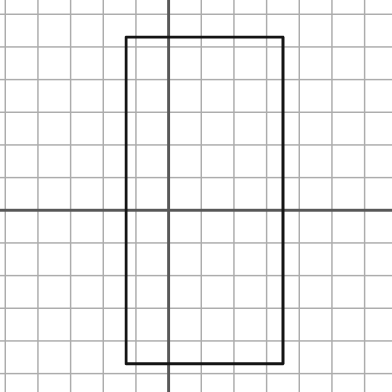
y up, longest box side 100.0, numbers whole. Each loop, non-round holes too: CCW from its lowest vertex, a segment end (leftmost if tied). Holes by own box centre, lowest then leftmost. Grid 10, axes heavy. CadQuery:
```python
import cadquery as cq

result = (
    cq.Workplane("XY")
    .moveTo(-13.0, -47.0)
    .lineTo(35.0, -47.0)
    .lineTo(35.0, 53.0)
    .lineTo(-13.0, 53.0)
    .close()
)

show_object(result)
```